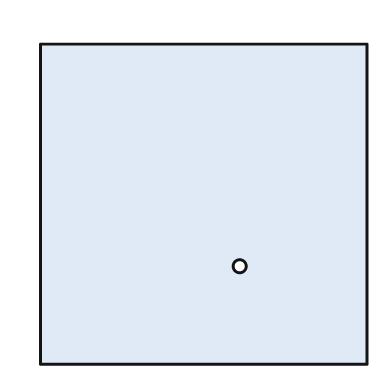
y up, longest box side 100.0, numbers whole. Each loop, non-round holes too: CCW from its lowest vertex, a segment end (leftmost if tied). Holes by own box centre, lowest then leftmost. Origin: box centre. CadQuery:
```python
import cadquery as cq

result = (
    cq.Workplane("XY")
    .moveTo(-50.0, -49.0)
    .lineTo(50.0, -49.0)
    .lineTo(50.0, 49.0)
    .lineTo(-50.0, 49.0)
    .close()
    .moveTo(11.0, -19.0)
    .circle(2.0)
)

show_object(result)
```